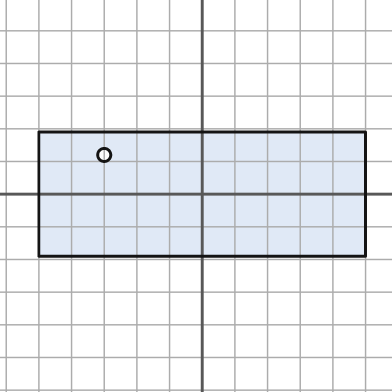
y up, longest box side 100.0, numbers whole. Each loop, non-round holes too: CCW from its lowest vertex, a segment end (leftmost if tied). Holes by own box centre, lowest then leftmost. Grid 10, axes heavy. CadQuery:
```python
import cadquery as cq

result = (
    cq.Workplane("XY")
    .moveTo(-50.0, -19.0)
    .lineTo(50.0, -19.0)
    .lineTo(50.0, 19.0)
    .lineTo(-50.0, 19.0)
    .close()
    .moveTo(-30.0, 12.0)
    .circle(2.0)
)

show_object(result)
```